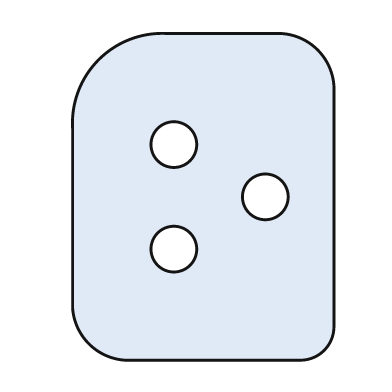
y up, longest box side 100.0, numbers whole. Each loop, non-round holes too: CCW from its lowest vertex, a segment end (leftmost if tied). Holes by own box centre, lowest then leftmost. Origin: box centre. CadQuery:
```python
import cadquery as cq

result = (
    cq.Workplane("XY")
    .moveTo(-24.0, -50.0)
    .lineTo(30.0, -50.0)
    .threePointArc((37.0, -47.0), (40.0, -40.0))
    .lineTo(40.0, 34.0)
    .threePointArc((35.0, 45.0), (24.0, 50.0))
    .lineTo(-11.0, 50.0)
    .threePointArc((-32.0, 42.0), (-40.0, 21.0))
    .lineTo(-40.0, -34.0)
    .threePointArc((-35.0, -45.0), (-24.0, -50.0))
    .close()
    .moveTo(-9.0, -16.0)
    .circle(7.0)
    .moveTo(19.0, 0.0)
    .circle(7.0)
    .moveTo(-9.0, 16.0)
    .circle(7.0)
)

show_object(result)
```